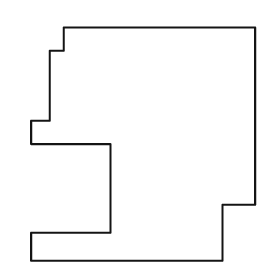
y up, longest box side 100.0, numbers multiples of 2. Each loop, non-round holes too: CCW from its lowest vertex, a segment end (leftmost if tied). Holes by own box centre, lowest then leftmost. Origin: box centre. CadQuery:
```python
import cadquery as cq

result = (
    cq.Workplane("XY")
    .moveTo(-48.0, -50.0)
    .lineTo(34.0, -50.0)
    .lineTo(34.0, -26.0)
    .lineTo(48.0, -26.0)
    .lineTo(48.0, 50.0)
    .lineTo(-34.0, 50.0)
    .lineTo(-34.0, 40.0)
    .lineTo(-40.0, 40.0)
    .lineTo(-40.0, 10.0)
    .lineTo(-48.0, 10.0)
    .lineTo(-48.0, 0.0)
    .lineTo(-14.0, 0.0)
    .lineTo(-14.0, -38.0)
    .lineTo(-48.0, -38.0)
    .close()
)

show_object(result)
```